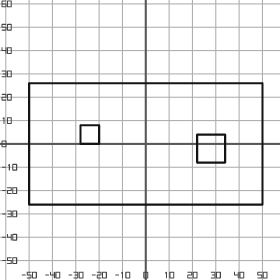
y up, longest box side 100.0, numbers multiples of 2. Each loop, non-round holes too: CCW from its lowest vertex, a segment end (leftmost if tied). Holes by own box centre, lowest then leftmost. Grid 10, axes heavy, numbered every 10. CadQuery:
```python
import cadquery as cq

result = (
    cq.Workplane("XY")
    .moveTo(-50.0, -26.0)
    .lineTo(50.0, -26.0)
    .lineTo(50.0, 26.0)
    .lineTo(-50.0, 26.0)
    .close()
    .moveTo(22.0, -8.0)
    .lineTo(34.0, -8.0)
    .lineTo(34.0, 4.0)
    .lineTo(22.0, 4.0)
    .close()
    .moveTo(-28.0, 0.0)
    .lineTo(-20.0, 0.0)
    .lineTo(-20.0, 8.0)
    .lineTo(-28.0, 8.0)
    .close()
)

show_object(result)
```